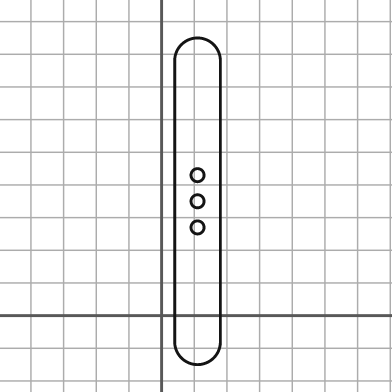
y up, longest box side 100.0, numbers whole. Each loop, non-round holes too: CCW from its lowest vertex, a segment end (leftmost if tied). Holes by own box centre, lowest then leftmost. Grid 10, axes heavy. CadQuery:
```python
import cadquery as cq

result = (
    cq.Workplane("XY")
    .moveTo(4.0, -8.0)
    .threePointArc((11.0, -15.0), (18.0, -8.0))
    .lineTo(18.0, 78.0)
    .threePointArc((11.0, 85.0), (4.0, 78.0))
    .close()
    .moveTo(11.0, 27.0)
    .circle(2.0)
    .moveTo(11.0, 35.0)
    .circle(2.0)
    .moveTo(11.0, 43.0)
    .circle(2.0)
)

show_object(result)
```